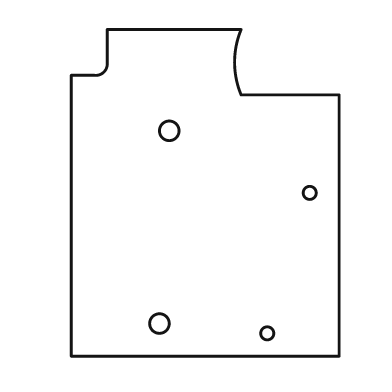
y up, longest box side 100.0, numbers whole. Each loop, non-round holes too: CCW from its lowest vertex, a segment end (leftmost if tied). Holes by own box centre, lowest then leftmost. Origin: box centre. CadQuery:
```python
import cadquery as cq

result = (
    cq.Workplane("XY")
    .moveTo(-41.0, -50.0)
    .lineTo(41.0, -50.0)
    .lineTo(41.0, 30.0)
    .lineTo(11.0, 30.0)
    .threePointArc((9.0, 40.0), (11.0, 50.0))
    .lineTo(-30.0, 50.0)
    .lineTo(-30.0, 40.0)
    .threePointArc((-31.0, 37.0), (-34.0, 36.0))
    .lineTo(-41.0, 36.0)
    .close()
    .moveTo(19.0, -43.0)
    .circle(2.0)
    .moveTo(-14.0, -40.0)
    .circle(3.0)
    .moveTo(32.0, 0.0)
    .circle(2.0)
    .moveTo(-11.0, 19.0)
    .circle(3.0)
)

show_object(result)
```